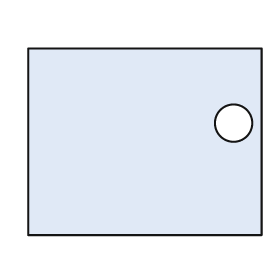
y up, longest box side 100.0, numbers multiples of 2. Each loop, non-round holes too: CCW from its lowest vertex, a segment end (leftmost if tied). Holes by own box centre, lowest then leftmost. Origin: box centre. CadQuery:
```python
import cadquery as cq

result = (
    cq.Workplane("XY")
    .moveTo(-50.0, -40.0)
    .lineTo(50.0, -40.0)
    .lineTo(50.0, 40.0)
    .lineTo(-50.0, 40.0)
    .close()
    .moveTo(38.0, 8.0)
    .circle(8.0)
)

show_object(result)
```